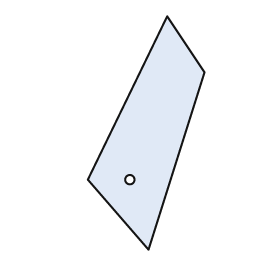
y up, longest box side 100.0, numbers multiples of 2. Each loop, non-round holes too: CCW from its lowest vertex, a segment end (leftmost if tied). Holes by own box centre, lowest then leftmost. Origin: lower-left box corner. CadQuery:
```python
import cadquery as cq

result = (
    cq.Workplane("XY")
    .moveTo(26.0, 0.0)
    .lineTo(50.0, 76.0)
    .lineTo(34.0, 100.0)
    .lineTo(0.0, 30.0)
    .close()
    .moveTo(18.0, 30.0)
    .circle(2.0)
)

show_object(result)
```